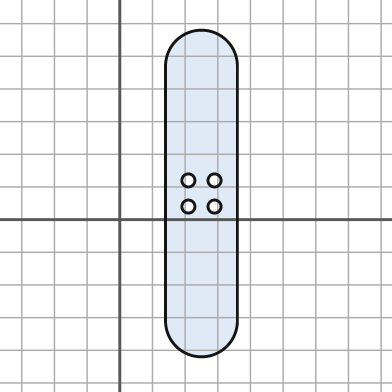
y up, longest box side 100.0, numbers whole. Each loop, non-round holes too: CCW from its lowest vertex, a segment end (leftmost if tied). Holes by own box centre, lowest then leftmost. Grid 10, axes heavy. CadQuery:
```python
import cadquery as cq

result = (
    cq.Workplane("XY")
    .moveTo(14.0, -31.0)
    .threePointArc((25.0, -42.0), (36.0, -31.0))
    .lineTo(36.0, 47.0)
    .threePointArc((25.0, 58.0), (14.0, 47.0))
    .close()
    .moveTo(21.0, 4.0)
    .circle(2.0)
    .moveTo(29.0, 4.0)
    .circle(2.0)
    .moveTo(21.0, 12.0)
    .circle(2.0)
    .moveTo(29.0, 12.0)
    .circle(2.0)
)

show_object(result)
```